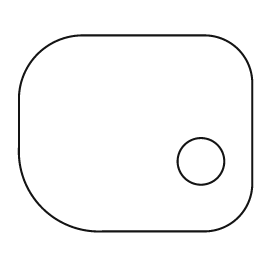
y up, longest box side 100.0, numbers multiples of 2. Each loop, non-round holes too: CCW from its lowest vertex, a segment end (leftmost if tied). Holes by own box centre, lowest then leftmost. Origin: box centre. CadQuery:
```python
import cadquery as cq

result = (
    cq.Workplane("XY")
    .moveTo(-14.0, -42.0)
    .lineTo(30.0, -42.0)
    .threePointArc((44.0, -36.0), (50.0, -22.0))
    .lineTo(50.0, 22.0)
    .threePointArc((44.0, 36.0), (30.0, 42.0))
    .lineTo(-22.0, 42.0)
    .threePointArc((-42.0, 34.0), (-50.0, 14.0))
    .lineTo(-50.0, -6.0)
    .threePointArc((-40.0, -32.0), (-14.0, -42.0))
    .close()
    .moveTo(28.0, -12.0)
    .circle(10.0)
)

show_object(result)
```